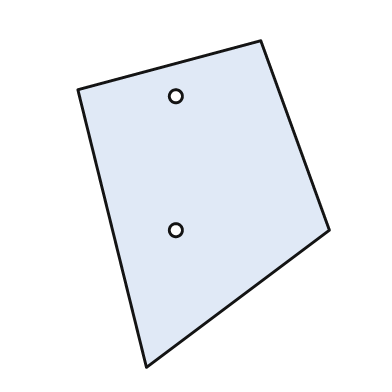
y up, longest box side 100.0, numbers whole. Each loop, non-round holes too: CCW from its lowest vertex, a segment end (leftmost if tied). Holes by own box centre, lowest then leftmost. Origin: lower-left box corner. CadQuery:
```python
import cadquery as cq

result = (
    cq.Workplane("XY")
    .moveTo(21.0, 0.0)
    .lineTo(77.0, 42.0)
    .lineTo(56.0, 100.0)
    .lineTo(0.0, 85.0)
    .close()
    .moveTo(30.0, 42.0)
    .circle(2.0)
    .moveTo(30.0, 83.0)
    .circle(2.0)
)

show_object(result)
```